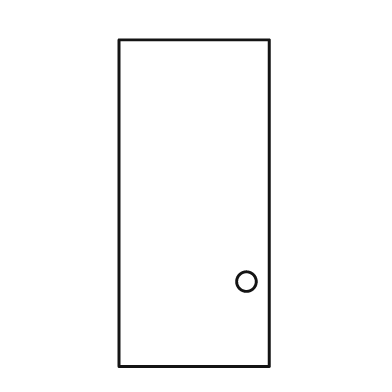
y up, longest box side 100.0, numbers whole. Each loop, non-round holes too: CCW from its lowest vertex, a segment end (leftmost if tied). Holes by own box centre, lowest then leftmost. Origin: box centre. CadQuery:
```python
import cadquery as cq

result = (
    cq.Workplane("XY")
    .moveTo(-23.0, -50.0)
    .lineTo(23.0, -50.0)
    .lineTo(23.0, 50.0)
    .lineTo(-23.0, 50.0)
    .close()
    .moveTo(16.0, -24.0)
    .circle(3.0)
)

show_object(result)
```